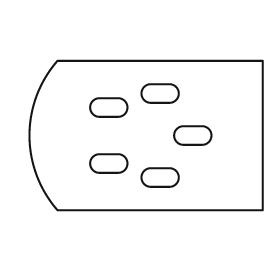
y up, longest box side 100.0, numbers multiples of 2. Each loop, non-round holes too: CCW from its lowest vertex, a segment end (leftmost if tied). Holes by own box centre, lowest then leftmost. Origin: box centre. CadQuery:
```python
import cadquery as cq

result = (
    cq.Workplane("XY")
    .moveTo(-38.0, -32.0)
    .lineTo(50.0, -32.0)
    .lineTo(50.0, 32.0)
    .lineTo(-38.0, 32.0)
    .threePointArc((-50.0, 0.0), (-38.0, -32.0))
    .close()
    .moveTo(2.0, -22.0)
    .lineTo(10.0, -22.0)
    .threePointArc((14.0, -18.0), (10.0, -14.0))
    .lineTo(2.0, -14.0)
    .threePointArc((-2.0, -18.0), (2.0, -22.0))
    .close()
    .moveTo(-20.0, -16.0)
    .lineTo(-12.0, -16.0)
    .threePointArc((-8.0, -12.0), (-12.0, -8.0))
    .lineTo(-20.0, -8.0)
    .threePointArc((-24.0, -12.0), (-20.0, -16.0))
    .close()
    .moveTo(16.0, -4.0)
    .lineTo(24.0, -4.0)
    .threePointArc((28.0, 0.0), (24.0, 4.0))
    .lineTo(16.0, 4.0)
    .threePointArc((12.0, 0.0), (16.0, -4.0))
    .close()
    .moveTo(-20.0, 8.0)
    .lineTo(-12.0, 8.0)
    .threePointArc((-8.0, 12.0), (-12.0, 16.0))
    .lineTo(-20.0, 16.0)
    .threePointArc((-24.0, 12.0), (-20.0, 8.0))
    .close()
    .moveTo(2.0, 14.0)
    .lineTo(10.0, 14.0)
    .threePointArc((14.0, 18.0), (10.0, 22.0))
    .lineTo(2.0, 22.0)
    .threePointArc((-2.0, 18.0), (2.0, 14.0))
    .close()
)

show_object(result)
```